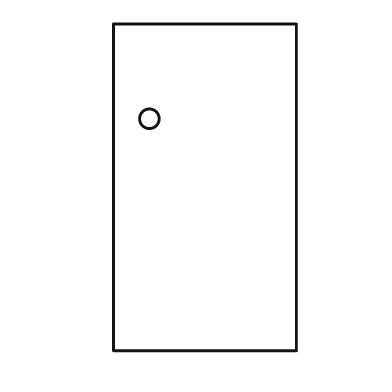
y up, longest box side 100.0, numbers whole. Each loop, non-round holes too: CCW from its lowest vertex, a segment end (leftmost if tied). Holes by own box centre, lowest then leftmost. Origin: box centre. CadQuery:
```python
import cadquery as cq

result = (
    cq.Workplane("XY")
    .moveTo(-28.0, -50.0)
    .lineTo(28.0, -50.0)
    .lineTo(28.0, 50.0)
    .lineTo(-28.0, 50.0)
    .close()
    .moveTo(-17.0, 21.0)
    .circle(3.0)
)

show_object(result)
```